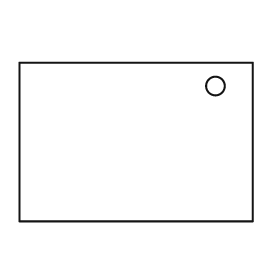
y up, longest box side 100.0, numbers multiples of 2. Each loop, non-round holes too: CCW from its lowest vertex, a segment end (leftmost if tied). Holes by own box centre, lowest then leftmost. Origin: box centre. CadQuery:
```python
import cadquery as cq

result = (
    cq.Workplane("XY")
    .moveTo(-50.0, -34.0)
    .lineTo(50.0, -34.0)
    .lineTo(50.0, 34.0)
    .lineTo(-50.0, 34.0)
    .close()
    .moveTo(34.0, 24.0)
    .circle(4.0)
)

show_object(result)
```